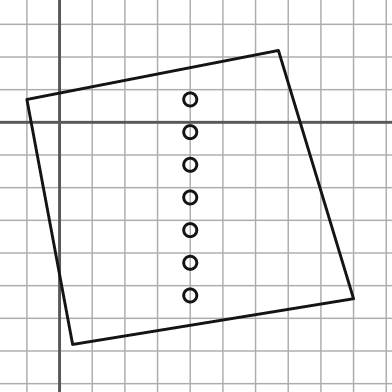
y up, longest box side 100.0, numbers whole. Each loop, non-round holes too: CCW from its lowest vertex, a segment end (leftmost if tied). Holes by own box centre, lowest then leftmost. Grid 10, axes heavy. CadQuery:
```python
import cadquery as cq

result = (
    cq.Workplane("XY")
    .moveTo(4.0, -68.0)
    .lineTo(90.0, -54.0)
    .lineTo(67.0, 22.0)
    .lineTo(-10.0, 7.0)
    .close()
    .moveTo(40.0, -53.0)
    .circle(2.0)
    .moveTo(40.0, -43.0)
    .circle(2.0)
    .moveTo(40.0, -33.0)
    .circle(2.0)
    .moveTo(40.0, -23.0)
    .circle(2.0)
    .moveTo(40.0, -13.0)
    .circle(2.0)
    .moveTo(40.0, -3.0)
    .circle(2.0)
    .moveTo(40.0, 7.0)
    .circle(2.0)
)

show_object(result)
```